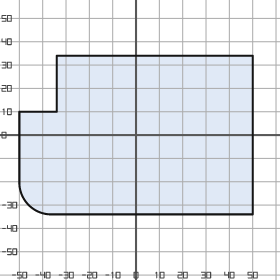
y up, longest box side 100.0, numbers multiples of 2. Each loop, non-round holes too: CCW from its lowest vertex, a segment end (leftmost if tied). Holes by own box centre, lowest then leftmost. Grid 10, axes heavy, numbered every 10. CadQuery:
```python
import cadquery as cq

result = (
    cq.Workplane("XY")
    .moveTo(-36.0, -34.0)
    .lineTo(50.0, -34.0)
    .lineTo(50.0, 34.0)
    .lineTo(-34.0, 34.0)
    .lineTo(-34.0, 10.0)
    .lineTo(-50.0, 10.0)
    .lineTo(-50.0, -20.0)
    .threePointArc((-46.0, -30.0), (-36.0, -34.0))
    .close()
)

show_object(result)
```